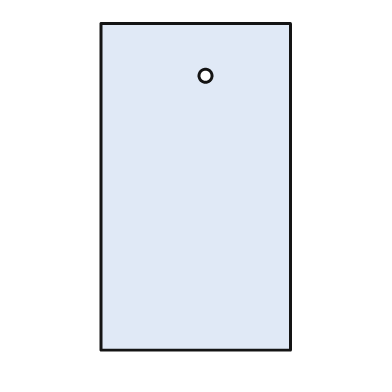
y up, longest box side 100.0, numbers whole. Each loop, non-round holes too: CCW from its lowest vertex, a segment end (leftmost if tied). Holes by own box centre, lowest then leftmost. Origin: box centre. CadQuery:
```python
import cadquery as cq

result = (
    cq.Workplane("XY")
    .moveTo(-29.0, -50.0)
    .lineTo(29.0, -50.0)
    .lineTo(29.0, 50.0)
    .lineTo(-29.0, 50.0)
    .close()
    .moveTo(3.0, 34.0)
    .circle(2.0)
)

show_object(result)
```